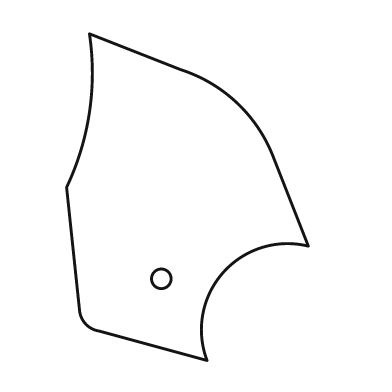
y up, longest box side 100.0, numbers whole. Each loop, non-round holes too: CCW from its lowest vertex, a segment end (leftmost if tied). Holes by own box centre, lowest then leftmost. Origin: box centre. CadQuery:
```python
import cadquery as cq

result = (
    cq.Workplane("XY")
    .moveTo(6.0, -50.0)
    .threePointArc((11.0, -23.0), (37.0, -15.0))
    .lineTo(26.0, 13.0)
    .threePointArc((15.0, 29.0), (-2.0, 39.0))
    .lineTo(-30.0, 50.0)
    .threePointArc((-30.0, 26.0), (-37.0, 3.0))
    .lineTo(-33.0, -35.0)
    .threePointArc((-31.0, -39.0), (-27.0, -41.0))
    .close()
    .moveTo(-8.0, -25.0)
    .circle(3.0)
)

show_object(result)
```